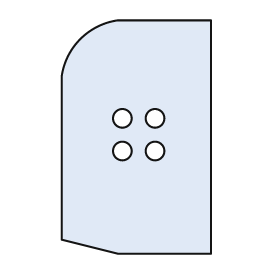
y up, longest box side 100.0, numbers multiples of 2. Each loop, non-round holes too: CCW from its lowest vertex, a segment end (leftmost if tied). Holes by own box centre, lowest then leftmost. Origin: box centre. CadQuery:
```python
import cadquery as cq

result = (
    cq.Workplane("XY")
    .moveTo(-8.0, -50.0)
    .lineTo(32.0, -50.0)
    .lineTo(32.0, 50.0)
    .lineTo(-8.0, 50.0)
    .threePointArc((-24.0, 42.0), (-32.0, 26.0))
    .lineTo(-32.0, -44.0)
    .close()
    .moveTo(-6.0, -6.0)
    .circle(4.0)
    .moveTo(8.0, -6.0)
    .circle(4.0)
    .moveTo(-6.0, 8.0)
    .circle(4.0)
    .moveTo(8.0, 8.0)
    .circle(4.0)
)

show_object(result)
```